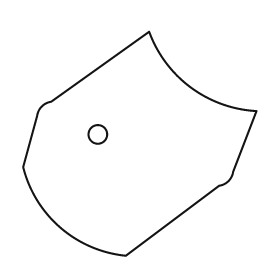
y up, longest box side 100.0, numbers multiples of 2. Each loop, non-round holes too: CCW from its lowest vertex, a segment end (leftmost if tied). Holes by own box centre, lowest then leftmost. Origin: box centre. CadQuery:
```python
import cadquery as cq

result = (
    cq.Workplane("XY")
    .moveTo(-6.0, -48.0)
    .lineTo(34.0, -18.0)
    .threePointArc((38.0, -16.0), (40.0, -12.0))
    .lineTo(50.0, 14.0)
    .threePointArc((22.0, 24.0), (4.0, 48.0))
    .lineTo(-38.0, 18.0)
    .threePointArc((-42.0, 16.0), (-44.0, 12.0))
    .lineTo(-50.0, -10.0)
    .threePointArc((-34.0, -36.0), (-6.0, -48.0))
    .close()
    .moveTo(-18.0, 4.0)
    .circle(4.0)
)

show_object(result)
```